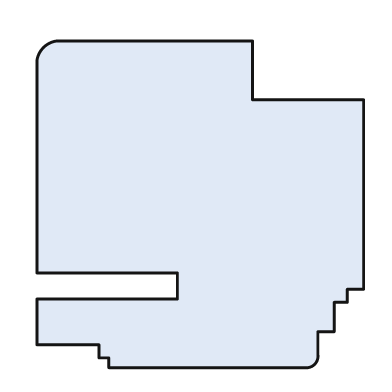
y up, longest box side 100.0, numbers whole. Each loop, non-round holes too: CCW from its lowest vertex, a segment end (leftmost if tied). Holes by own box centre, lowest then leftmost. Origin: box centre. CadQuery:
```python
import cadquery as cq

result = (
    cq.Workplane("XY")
    .moveTo(-28.0, -50.0)
    .lineTo(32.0, -50.0)
    .threePointArc((35.0, -49.0), (36.0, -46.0))
    .lineTo(36.0, -39.0)
    .lineTo(41.0, -39.0)
    .lineTo(41.0, -30.0)
    .lineTo(45.0, -30.0)
    .lineTo(45.0, -26.0)
    .lineTo(50.0, -26.0)
    .lineTo(50.0, 32.0)
    .lineTo(16.0, 32.0)
    .lineTo(16.0, 50.0)
    .lineTo(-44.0, 50.0)
    .threePointArc((-48.0, 48.0), (-50.0, 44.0))
    .lineTo(-50.0, -21.0)
    .lineTo(-7.0, -21.0)
    .lineTo(-7.0, -29.0)
    .lineTo(-50.0, -29.0)
    .lineTo(-50.0, -43.0)
    .lineTo(-31.0, -43.0)
    .lineTo(-31.0, -47.0)
    .lineTo(-28.0, -47.0)
    .close()
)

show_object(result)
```